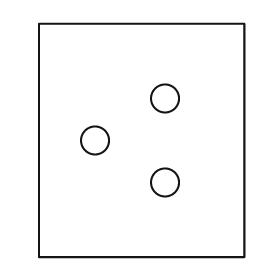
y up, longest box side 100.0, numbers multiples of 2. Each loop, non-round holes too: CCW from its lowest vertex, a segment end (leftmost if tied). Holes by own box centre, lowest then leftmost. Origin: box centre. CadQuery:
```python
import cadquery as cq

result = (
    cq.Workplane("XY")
    .moveTo(-44.0, -50.0)
    .lineTo(44.0, -50.0)
    .lineTo(44.0, 50.0)
    .lineTo(-44.0, 50.0)
    .close()
    .moveTo(10.0, -18.0)
    .circle(6.0)
    .moveTo(-20.0, 0.0)
    .circle(6.0)
    .moveTo(10.0, 18.0)
    .circle(6.0)
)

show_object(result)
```